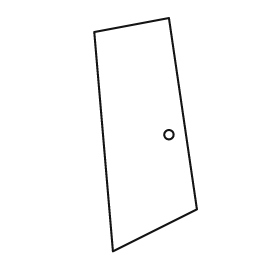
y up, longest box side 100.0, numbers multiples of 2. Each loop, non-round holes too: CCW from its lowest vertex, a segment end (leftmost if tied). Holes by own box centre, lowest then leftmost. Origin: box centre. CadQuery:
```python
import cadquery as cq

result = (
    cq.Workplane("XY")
    .moveTo(-14.0, -50.0)
    .lineTo(22.0, -32.0)
    .lineTo(10.0, 50.0)
    .lineTo(-22.0, 44.0)
    .close()
    .moveTo(10.0, 0.0)
    .circle(2.0)
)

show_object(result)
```